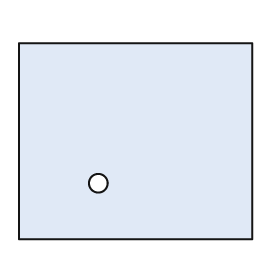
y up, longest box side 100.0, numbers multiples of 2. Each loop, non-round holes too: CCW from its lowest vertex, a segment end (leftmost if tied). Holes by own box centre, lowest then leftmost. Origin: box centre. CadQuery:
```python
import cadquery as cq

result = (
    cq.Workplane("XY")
    .moveTo(-50.0, -42.0)
    .lineTo(50.0, -42.0)
    .lineTo(50.0, 42.0)
    .lineTo(-50.0, 42.0)
    .close()
    .moveTo(-16.0, -18.0)
    .circle(4.0)
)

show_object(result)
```